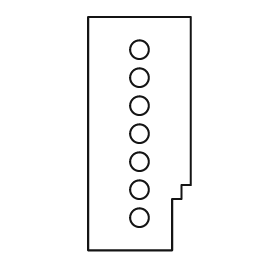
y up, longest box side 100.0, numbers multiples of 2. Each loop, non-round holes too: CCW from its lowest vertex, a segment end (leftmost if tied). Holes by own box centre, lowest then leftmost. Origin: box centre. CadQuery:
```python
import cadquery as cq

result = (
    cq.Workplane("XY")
    .moveTo(-22.0, -50.0)
    .lineTo(14.0, -50.0)
    .lineTo(14.0, -28.0)
    .lineTo(18.0, -28.0)
    .lineTo(18.0, -22.0)
    .lineTo(22.0, -22.0)
    .lineTo(22.0, 50.0)
    .lineTo(-22.0, 50.0)
    .close()
    .moveTo(0.0, -36.0)
    .circle(4.0)
    .moveTo(0.0, -24.0)
    .circle(4.0)
    .moveTo(0.0, -12.0)
    .circle(4.0)
    .moveTo(0.0, 0.0)
    .circle(4.0)
    .moveTo(0.0, 12.0)
    .circle(4.0)
    .moveTo(0.0, 24.0)
    .circle(4.0)
    .moveTo(0.0, 36.0)
    .circle(4.0)
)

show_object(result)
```